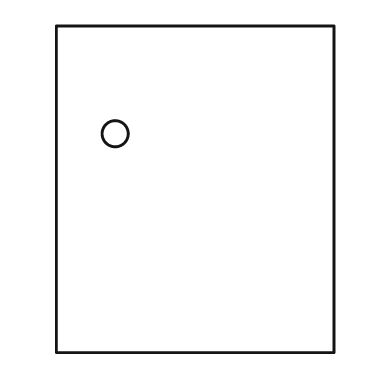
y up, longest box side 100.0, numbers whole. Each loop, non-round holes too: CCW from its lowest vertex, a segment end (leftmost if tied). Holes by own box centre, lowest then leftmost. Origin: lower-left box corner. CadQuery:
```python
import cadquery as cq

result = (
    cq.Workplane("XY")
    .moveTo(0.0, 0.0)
    .lineTo(85.0, 0.0)
    .lineTo(85.0, 100.0)
    .lineTo(0.0, 100.0)
    .close()
    .moveTo(18.0, 67.0)
    .circle(4.0)
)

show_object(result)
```